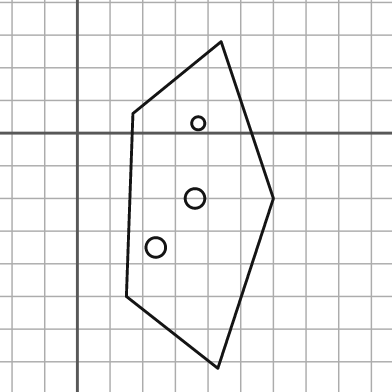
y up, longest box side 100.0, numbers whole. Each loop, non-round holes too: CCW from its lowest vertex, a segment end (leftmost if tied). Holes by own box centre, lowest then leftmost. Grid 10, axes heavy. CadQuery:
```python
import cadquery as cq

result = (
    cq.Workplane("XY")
    .moveTo(43.0, -72.0)
    .lineTo(60.0, -20.0)
    .lineTo(44.0, 28.0)
    .lineTo(17.0, 6.0)
    .lineTo(15.0, -50.0)
    .close()
    .moveTo(24.0, -35.0)
    .circle(3.0)
    .moveTo(36.0, -20.0)
    .circle(3.0)
    .moveTo(37.0, 3.0)
    .circle(2.0)
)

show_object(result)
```